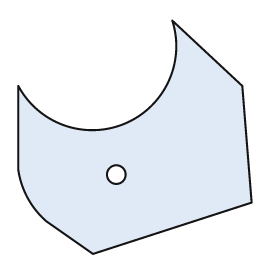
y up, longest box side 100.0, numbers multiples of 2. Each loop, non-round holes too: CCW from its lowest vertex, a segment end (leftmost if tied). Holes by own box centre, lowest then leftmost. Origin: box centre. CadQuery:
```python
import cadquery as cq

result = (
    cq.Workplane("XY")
    .moveTo(-18.0, -50.0)
    .lineTo(50.0, -28.0)
    .lineTo(46.0, 22.0)
    .lineTo(16.0, 50.0)
    .threePointArc((-4.0, 6.0), (-50.0, 22.0))
    .lineTo(-50.0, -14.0)
    .threePointArc((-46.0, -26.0), (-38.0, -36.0))
    .close()
    .moveTo(-8.0, -16.0)
    .circle(4.0)
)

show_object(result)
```